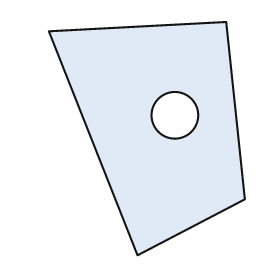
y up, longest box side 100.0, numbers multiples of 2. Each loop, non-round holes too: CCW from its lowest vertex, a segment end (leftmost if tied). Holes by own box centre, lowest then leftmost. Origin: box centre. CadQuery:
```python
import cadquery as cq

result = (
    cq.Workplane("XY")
    .moveTo(-4.0, -50.0)
    .lineTo(42.0, -26.0)
    .lineTo(34.0, 50.0)
    .lineTo(-42.0, 46.0)
    .close()
    .moveTo(12.0, 10.0)
    .circle(10.0)
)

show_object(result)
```